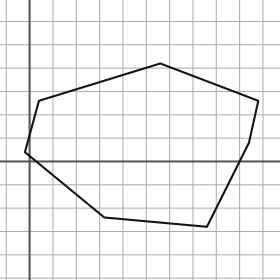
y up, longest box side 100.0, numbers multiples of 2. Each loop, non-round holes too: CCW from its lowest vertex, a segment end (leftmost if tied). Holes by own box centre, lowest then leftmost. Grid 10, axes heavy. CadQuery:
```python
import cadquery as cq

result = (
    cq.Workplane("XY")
    .moveTo(76.0, -28.0)
    .lineTo(94.0, 8.0)
    .lineTo(98.0, 26.0)
    .lineTo(56.0, 42.0)
    .lineTo(4.0, 26.0)
    .lineTo(-2.0, 4.0)
    .lineTo(32.0, -24.0)
    .close()
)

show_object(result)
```